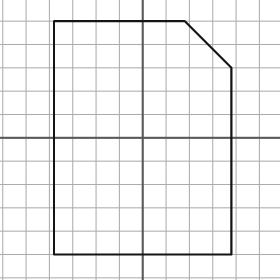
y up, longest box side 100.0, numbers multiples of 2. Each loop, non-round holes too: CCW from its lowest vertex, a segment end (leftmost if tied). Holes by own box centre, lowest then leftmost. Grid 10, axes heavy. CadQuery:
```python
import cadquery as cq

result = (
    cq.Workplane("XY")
    .moveTo(-38.0, -50.0)
    .lineTo(38.0, -50.0)
    .lineTo(38.0, 30.0)
    .lineTo(18.0, 50.0)
    .lineTo(-38.0, 50.0)
    .close()
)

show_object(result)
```